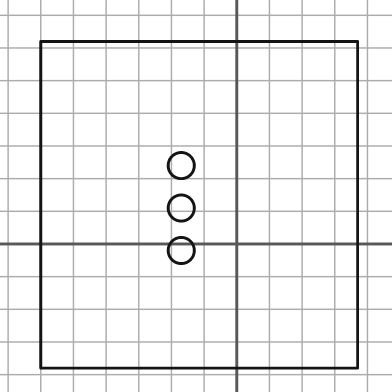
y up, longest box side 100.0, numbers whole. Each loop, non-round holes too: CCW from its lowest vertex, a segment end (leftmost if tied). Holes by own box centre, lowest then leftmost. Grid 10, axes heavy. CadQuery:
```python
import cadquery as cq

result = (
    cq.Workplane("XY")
    .moveTo(-60.0, -38.0)
    .lineTo(37.0, -38.0)
    .lineTo(37.0, 62.0)
    .lineTo(-60.0, 62.0)
    .close()
    .moveTo(-17.0, -2.0)
    .circle(4.0)
    .moveTo(-17.0, 11.0)
    .circle(4.0)
    .moveTo(-17.0, 24.0)
    .circle(4.0)
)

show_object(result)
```